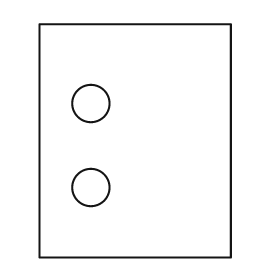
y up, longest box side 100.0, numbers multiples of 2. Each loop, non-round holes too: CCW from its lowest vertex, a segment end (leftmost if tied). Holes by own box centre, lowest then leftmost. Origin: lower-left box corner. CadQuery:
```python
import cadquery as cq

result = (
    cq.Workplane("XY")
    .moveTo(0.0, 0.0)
    .lineTo(82.0, 0.0)
    .lineTo(82.0, 100.0)
    .lineTo(0.0, 100.0)
    .close()
    .moveTo(22.0, 30.0)
    .circle(8.0)
    .moveTo(22.0, 66.0)
    .circle(8.0)
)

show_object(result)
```